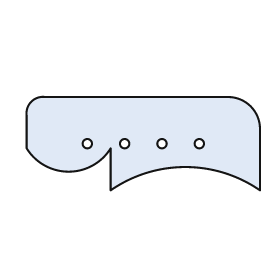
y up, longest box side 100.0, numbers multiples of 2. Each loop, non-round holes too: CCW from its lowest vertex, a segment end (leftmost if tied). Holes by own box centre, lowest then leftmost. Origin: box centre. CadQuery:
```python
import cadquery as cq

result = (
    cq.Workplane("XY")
    .moveTo(-14.0, -20.0)
    .threePointArc((18.0, -10.0), (50.0, -20.0))
    .lineTo(50.0, 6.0)
    .threePointArc((46.0, 16.0), (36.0, 20.0))
    .lineTo(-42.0, 20.0)
    .threePointArc((-48.0, 18.0), (-50.0, 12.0))
    .lineTo(-50.0, -2.0)
    .threePointArc((-32.0, -12.0), (-14.0, -2.0))
    .close()
    .moveTo(-24.0, 0.0)
    .circle(2.0)
    .moveTo(-8.0, 0.0)
    .circle(2.0)
    .moveTo(8.0, 0.0)
    .circle(2.0)
    .moveTo(24.0, 0.0)
    .circle(2.0)
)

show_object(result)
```